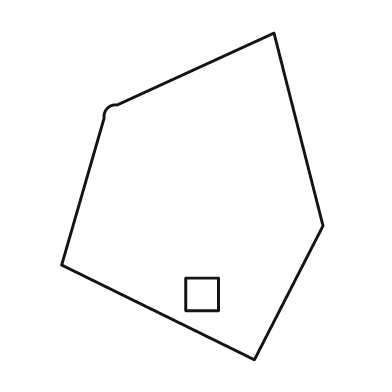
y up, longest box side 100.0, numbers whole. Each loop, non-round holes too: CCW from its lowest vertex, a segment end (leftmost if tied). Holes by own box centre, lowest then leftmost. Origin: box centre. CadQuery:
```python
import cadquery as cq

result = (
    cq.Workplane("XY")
    .moveTo(19.0, -50.0)
    .lineTo(40.0, -9.0)
    .lineTo(25.0, 50.0)
    .lineTo(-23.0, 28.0)
    .threePointArc((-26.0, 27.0), (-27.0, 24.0))
    .lineTo(-40.0, -21.0)
    .close()
    .moveTo(-2.0, -35.0)
    .lineTo(8.0, -35.0)
    .lineTo(8.0, -25.0)
    .lineTo(-2.0, -25.0)
    .close()
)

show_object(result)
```